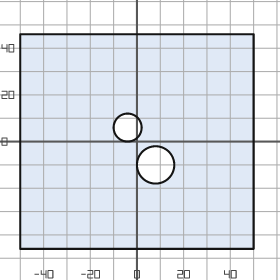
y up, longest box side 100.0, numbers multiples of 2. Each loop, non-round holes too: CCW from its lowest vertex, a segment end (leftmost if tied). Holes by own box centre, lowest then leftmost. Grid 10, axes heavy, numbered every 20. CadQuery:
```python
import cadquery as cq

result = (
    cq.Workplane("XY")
    .moveTo(-50.0, -46.0)
    .lineTo(50.0, -46.0)
    .lineTo(50.0, 46.0)
    .lineTo(-50.0, 46.0)
    .close()
    .moveTo(8.0, -10.0)
    .circle(8.0)
    .moveTo(-4.0, 6.0)
    .circle(6.0)
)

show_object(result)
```